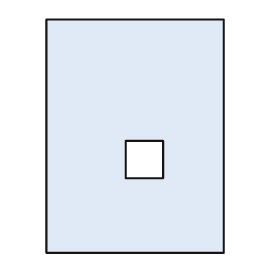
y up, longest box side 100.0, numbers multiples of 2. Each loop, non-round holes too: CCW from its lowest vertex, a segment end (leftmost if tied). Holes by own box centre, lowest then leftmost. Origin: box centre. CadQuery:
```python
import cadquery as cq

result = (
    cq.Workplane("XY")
    .moveTo(-38.0, -50.0)
    .lineTo(38.0, -50.0)
    .lineTo(38.0, 50.0)
    .lineTo(-38.0, 50.0)
    .close()
    .moveTo(-4.0, -18.0)
    .lineTo(12.0, -18.0)
    .lineTo(12.0, -2.0)
    .lineTo(-4.0, -2.0)
    .close()
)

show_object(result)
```